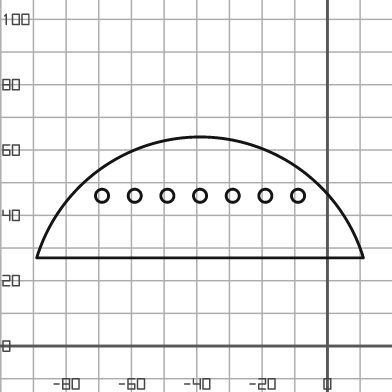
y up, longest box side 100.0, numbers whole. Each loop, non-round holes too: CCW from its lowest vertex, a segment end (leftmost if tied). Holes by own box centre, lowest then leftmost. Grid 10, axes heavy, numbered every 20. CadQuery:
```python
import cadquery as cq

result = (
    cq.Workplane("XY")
    .moveTo(-89.0, 27.0)
    .lineTo(11.0, 27.0)
    .threePointArc((-39.0, 64.0), (-89.0, 27.0))
    .close()
    .moveTo(-69.0, 46.0)
    .circle(2.0)
    .moveTo(-59.0, 46.0)
    .circle(2.0)
    .moveTo(-49.0, 46.0)
    .circle(2.0)
    .moveTo(-39.0, 46.0)
    .circle(2.0)
    .moveTo(-29.0, 46.0)
    .circle(2.0)
    .moveTo(-19.0, 46.0)
    .circle(2.0)
    .moveTo(-9.0, 46.0)
    .circle(2.0)
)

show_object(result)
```